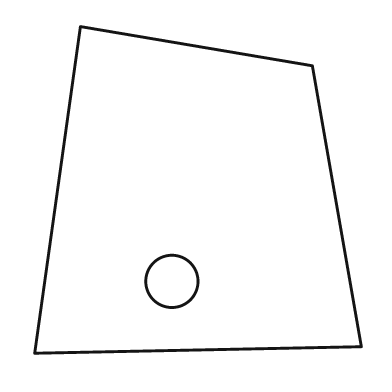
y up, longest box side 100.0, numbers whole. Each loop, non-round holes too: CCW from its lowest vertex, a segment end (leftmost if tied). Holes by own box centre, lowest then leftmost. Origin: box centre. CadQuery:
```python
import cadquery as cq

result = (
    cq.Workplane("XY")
    .moveTo(-50.0, -50.0)
    .lineTo(50.0, -48.0)
    .lineTo(35.0, 38.0)
    .lineTo(-36.0, 50.0)
    .close()
    .moveTo(-8.0, -28.0)
    .circle(8.0)
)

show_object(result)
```